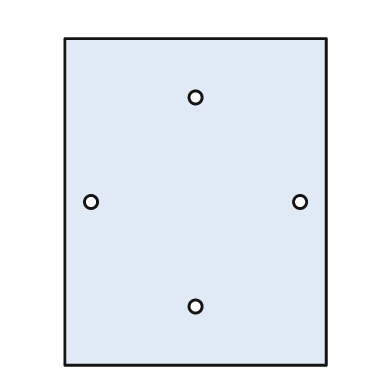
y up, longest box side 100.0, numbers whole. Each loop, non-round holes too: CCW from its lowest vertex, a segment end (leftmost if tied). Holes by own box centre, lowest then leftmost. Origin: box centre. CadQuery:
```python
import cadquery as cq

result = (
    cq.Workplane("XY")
    .moveTo(-40.0, -50.0)
    .lineTo(40.0, -50.0)
    .lineTo(40.0, 50.0)
    .lineTo(-40.0, 50.0)
    .close()
    .moveTo(0.0, -32.0)
    .circle(2.0)
    .moveTo(-32.0, 0.0)
    .circle(2.0)
    .moveTo(32.0, 0.0)
    .circle(2.0)
    .moveTo(0.0, 32.0)
    .circle(2.0)
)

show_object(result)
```